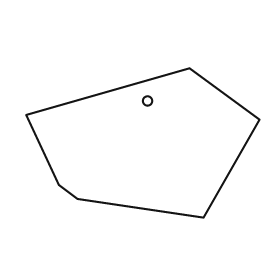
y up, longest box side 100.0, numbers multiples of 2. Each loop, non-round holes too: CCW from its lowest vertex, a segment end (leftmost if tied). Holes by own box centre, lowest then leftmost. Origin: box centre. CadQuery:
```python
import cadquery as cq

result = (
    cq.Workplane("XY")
    .moveTo(26.0, -32.0)
    .lineTo(50.0, 10.0)
    .lineTo(20.0, 32.0)
    .lineTo(-50.0, 12.0)
    .lineTo(-36.0, -18.0)
    .lineTo(-28.0, -24.0)
    .close()
    .moveTo(2.0, 18.0)
    .circle(2.0)
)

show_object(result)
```